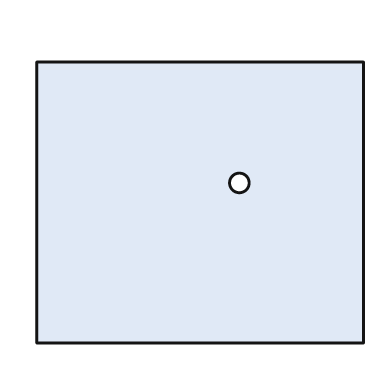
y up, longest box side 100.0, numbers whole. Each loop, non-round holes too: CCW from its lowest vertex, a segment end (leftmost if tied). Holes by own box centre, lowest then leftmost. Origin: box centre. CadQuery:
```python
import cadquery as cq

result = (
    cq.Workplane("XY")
    .moveTo(-50.0, -43.0)
    .lineTo(50.0, -43.0)
    .lineTo(50.0, 43.0)
    .lineTo(-50.0, 43.0)
    .close()
    .moveTo(12.0, 6.0)
    .circle(3.0)
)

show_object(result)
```